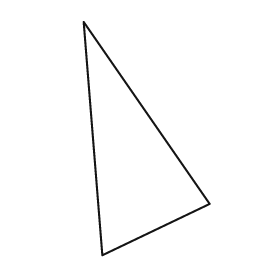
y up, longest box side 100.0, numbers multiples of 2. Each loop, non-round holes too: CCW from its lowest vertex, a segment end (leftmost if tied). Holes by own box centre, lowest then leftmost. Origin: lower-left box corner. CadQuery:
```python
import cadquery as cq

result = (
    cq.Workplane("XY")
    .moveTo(8.0, 0.0)
    .lineTo(54.0, 22.0)
    .lineTo(0.0, 100.0)
    .close()
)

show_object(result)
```